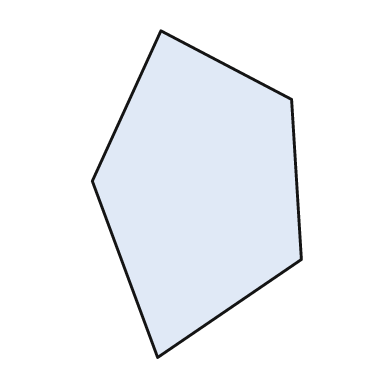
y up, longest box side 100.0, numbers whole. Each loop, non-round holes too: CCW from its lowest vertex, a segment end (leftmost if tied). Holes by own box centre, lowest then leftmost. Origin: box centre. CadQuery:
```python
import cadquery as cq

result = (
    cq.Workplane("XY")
    .moveTo(-12.0, -50.0)
    .lineTo(32.0, -20.0)
    .lineTo(29.0, 29.0)
    .lineTo(-11.0, 50.0)
    .lineTo(-32.0, 4.0)
    .close()
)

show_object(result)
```